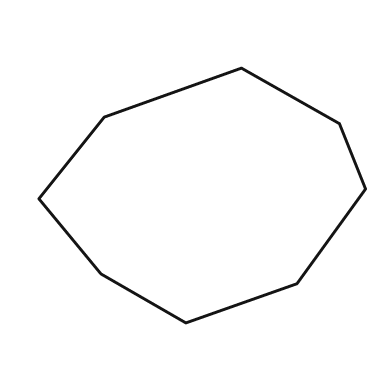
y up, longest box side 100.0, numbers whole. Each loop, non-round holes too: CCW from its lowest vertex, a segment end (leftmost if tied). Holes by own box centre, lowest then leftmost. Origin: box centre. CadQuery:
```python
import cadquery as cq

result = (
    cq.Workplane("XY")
    .moveTo(-5.0, -39.0)
    .lineTo(29.0, -27.0)
    .lineTo(50.0, 2.0)
    .lineTo(42.0, 22.0)
    .lineTo(12.0, 39.0)
    .lineTo(-30.0, 24.0)
    .lineTo(-50.0, -1.0)
    .lineTo(-31.0, -24.0)
    .close()
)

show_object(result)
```